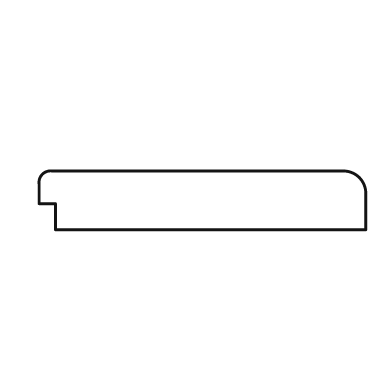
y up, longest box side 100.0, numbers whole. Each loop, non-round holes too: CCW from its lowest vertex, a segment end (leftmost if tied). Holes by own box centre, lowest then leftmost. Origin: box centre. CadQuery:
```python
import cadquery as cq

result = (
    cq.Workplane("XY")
    .moveTo(-45.0, -9.0)
    .lineTo(50.0, -9.0)
    .lineTo(50.0, 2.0)
    .threePointArc((48.0, 7.0), (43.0, 9.0))
    .lineTo(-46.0, 9.0)
    .threePointArc((-49.0, 8.0), (-50.0, 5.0))
    .lineTo(-50.0, -1.0)
    .lineTo(-45.0, -1.0)
    .close()
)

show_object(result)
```